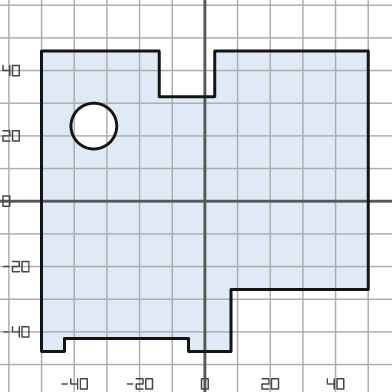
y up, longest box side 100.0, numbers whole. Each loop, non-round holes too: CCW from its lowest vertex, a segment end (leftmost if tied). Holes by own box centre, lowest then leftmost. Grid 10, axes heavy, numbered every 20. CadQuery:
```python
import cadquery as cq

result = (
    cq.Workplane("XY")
    .moveTo(-50.0, -46.0)
    .lineTo(-43.0, -46.0)
    .lineTo(-43.0, -42.0)
    .lineTo(-5.0, -42.0)
    .lineTo(-5.0, -46.0)
    .lineTo(8.0, -46.0)
    .lineTo(8.0, -27.0)
    .lineTo(50.0, -27.0)
    .lineTo(50.0, 46.0)
    .lineTo(3.0, 46.0)
    .lineTo(3.0, 32.0)
    .lineTo(-14.0, 32.0)
    .lineTo(-14.0, 46.0)
    .lineTo(-50.0, 46.0)
    .close()
    .moveTo(-34.0, 23.0)
    .circle(7.0)
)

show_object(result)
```